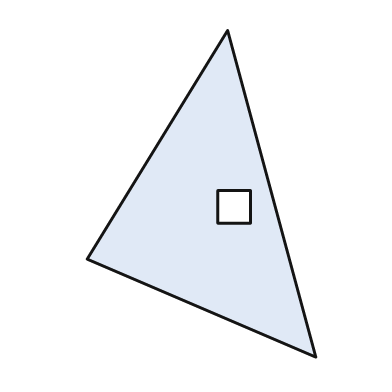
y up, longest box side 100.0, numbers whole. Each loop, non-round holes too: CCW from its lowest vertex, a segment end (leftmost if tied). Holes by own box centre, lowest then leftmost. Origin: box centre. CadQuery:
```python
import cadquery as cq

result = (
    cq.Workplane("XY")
    .moveTo(35.0, -50.0)
    .lineTo(8.0, 50.0)
    .lineTo(-35.0, -20.0)
    .close()
    .moveTo(5.0, -9.0)
    .lineTo(15.0, -9.0)
    .lineTo(15.0, 1.0)
    .lineTo(5.0, 1.0)
    .close()
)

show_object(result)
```